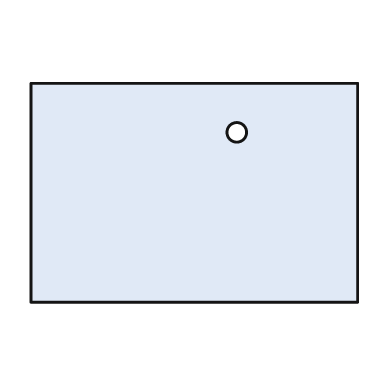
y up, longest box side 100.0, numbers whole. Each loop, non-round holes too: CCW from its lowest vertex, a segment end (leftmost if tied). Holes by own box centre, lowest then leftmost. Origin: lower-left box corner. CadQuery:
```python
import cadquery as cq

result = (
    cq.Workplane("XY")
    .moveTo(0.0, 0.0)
    .lineTo(100.0, 0.0)
    .lineTo(100.0, 67.0)
    .lineTo(0.0, 67.0)
    .close()
    .moveTo(63.0, 52.0)
    .circle(3.0)
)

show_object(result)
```